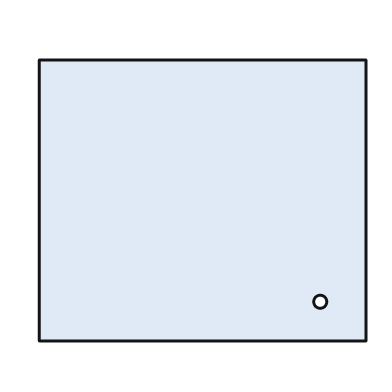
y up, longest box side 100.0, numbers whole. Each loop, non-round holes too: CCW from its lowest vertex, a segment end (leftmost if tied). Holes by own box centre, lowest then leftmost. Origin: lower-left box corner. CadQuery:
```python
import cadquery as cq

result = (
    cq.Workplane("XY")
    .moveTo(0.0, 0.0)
    .lineTo(100.0, 0.0)
    .lineTo(100.0, 86.0)
    .lineTo(0.0, 86.0)
    .close()
    .moveTo(86.0, 12.0)
    .circle(2.0)
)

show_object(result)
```